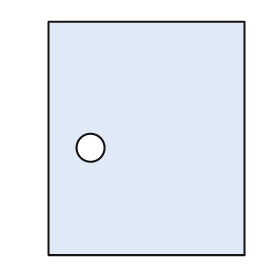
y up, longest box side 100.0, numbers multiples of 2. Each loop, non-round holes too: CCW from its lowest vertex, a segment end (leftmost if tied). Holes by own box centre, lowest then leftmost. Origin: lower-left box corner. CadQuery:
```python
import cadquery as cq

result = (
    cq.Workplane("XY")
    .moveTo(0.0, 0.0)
    .lineTo(84.0, 0.0)
    .lineTo(84.0, 100.0)
    .lineTo(0.0, 100.0)
    .close()
    .moveTo(18.0, 46.0)
    .circle(6.0)
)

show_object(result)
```